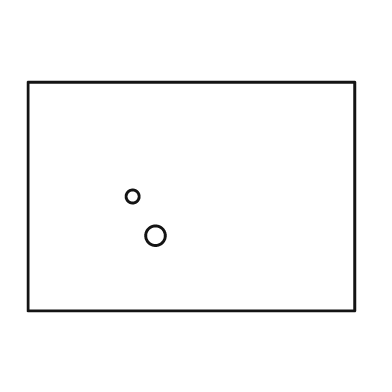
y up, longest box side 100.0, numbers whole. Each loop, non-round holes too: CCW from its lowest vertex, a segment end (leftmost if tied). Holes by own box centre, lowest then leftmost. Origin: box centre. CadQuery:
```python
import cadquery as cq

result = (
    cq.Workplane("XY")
    .moveTo(-50.0, -35.0)
    .lineTo(50.0, -35.0)
    .lineTo(50.0, 35.0)
    .lineTo(-50.0, 35.0)
    .close()
    .moveTo(-11.0, -12.0)
    .circle(3.0)
    .moveTo(-18.0, 0.0)
    .circle(2.0)
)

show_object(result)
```